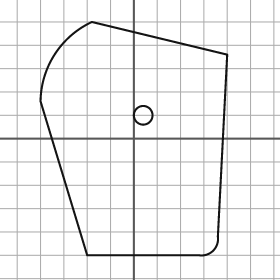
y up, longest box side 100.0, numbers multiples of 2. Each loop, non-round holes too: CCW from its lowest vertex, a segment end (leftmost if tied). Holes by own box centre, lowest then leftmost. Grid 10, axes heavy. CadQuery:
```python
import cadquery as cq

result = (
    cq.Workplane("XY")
    .moveTo(-20.0, -50.0)
    .lineTo(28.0, -50.0)
    .threePointArc((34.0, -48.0), (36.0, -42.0))
    .lineTo(40.0, 36.0)
    .lineTo(-18.0, 50.0)
    .threePointArc((-34.0, 36.0), (-40.0, 16.0))
    .close()
    .moveTo(4.0, 10.0)
    .circle(4.0)
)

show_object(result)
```